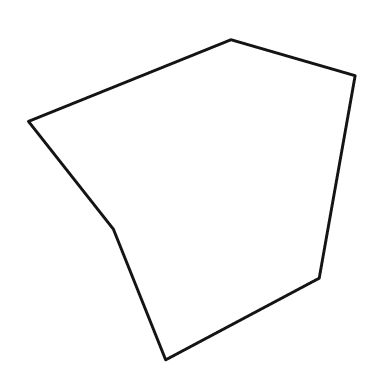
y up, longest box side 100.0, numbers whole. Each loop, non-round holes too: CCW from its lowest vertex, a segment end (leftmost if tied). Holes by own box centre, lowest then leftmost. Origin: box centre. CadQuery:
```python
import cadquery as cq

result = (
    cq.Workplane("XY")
    .moveTo(-8.0, -49.0)
    .lineTo(39.0, -24.0)
    .lineTo(50.0, 38.0)
    .lineTo(12.0, 49.0)
    .lineTo(-50.0, 24.0)
    .lineTo(-24.0, -9.0)
    .close()
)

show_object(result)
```